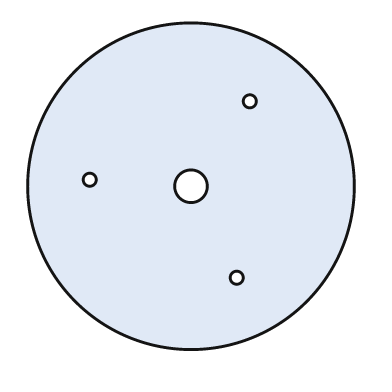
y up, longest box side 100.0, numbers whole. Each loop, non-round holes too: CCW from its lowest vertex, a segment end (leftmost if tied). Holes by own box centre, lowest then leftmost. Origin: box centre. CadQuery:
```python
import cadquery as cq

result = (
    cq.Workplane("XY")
    .moveTo(0.0, 0.0)
    .circle(50.0)
    .moveTo(14.0, -28.0)
    .circle(2.0)
    .moveTo(0.0, 0.0)
    .circle(5.0)
    .moveTo(-31.0, 2.0)
    .circle(2.0)
    .moveTo(18.0, 26.0)
    .circle(2.0)
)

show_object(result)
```